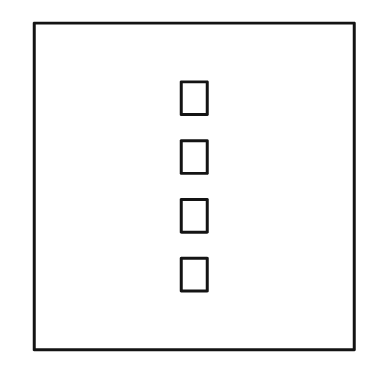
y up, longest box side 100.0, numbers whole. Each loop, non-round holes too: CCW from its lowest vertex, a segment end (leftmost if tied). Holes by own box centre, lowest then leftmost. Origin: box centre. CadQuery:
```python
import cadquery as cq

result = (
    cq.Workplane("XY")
    .moveTo(-49.0, -50.0)
    .lineTo(49.0, -50.0)
    .lineTo(49.0, 50.0)
    .lineTo(-49.0, 50.0)
    .close()
    .moveTo(-4.0, -32.0)
    .lineTo(4.0, -32.0)
    .lineTo(4.0, -22.0)
    .lineTo(-4.0, -22.0)
    .close()
    .moveTo(-4.0, -14.0)
    .lineTo(4.0, -14.0)
    .lineTo(4.0, -4.0)
    .lineTo(-4.0, -4.0)
    .close()
    .moveTo(-4.0, 4.0)
    .lineTo(4.0, 4.0)
    .lineTo(4.0, 14.0)
    .lineTo(-4.0, 14.0)
    .close()
    .moveTo(-4.0, 22.0)
    .lineTo(4.0, 22.0)
    .lineTo(4.0, 32.0)
    .lineTo(-4.0, 32.0)
    .close()
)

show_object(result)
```